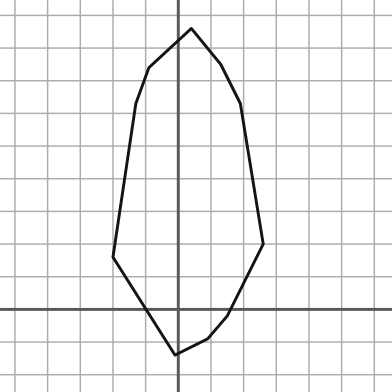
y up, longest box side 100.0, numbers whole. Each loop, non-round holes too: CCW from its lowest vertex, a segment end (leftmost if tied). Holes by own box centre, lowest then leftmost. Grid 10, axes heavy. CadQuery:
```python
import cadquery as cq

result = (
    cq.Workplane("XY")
    .moveTo(-1.0, -14.0)
    .lineTo(9.0, -9.0)
    .lineTo(15.0, -2.0)
    .lineTo(26.0, 20.0)
    .lineTo(19.0, 63.0)
    .lineTo(13.0, 75.0)
    .lineTo(4.0, 86.0)
    .lineTo(-9.0, 74.0)
    .lineTo(-13.0, 63.0)
    .lineTo(-20.0, 16.0)
    .close()
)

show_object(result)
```